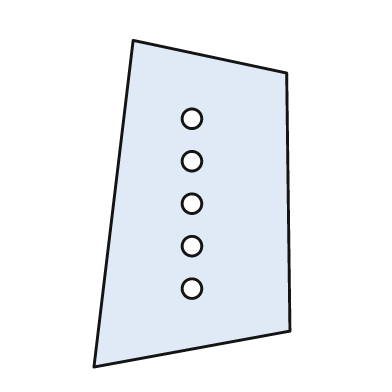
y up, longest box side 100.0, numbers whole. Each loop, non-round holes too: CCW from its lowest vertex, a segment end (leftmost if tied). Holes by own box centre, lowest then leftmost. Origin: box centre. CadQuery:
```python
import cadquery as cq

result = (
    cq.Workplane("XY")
    .moveTo(-30.0, -50.0)
    .lineTo(30.0, -39.0)
    .lineTo(29.0, 40.0)
    .lineTo(-18.0, 50.0)
    .close()
    .moveTo(0.0, -26.0)
    .circle(3.0)
    .moveTo(0.0, -13.0)
    .circle(3.0)
    .moveTo(0.0, 0.0)
    .circle(3.0)
    .moveTo(0.0, 13.0)
    .circle(3.0)
    .moveTo(0.0, 26.0)
    .circle(3.0)
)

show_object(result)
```